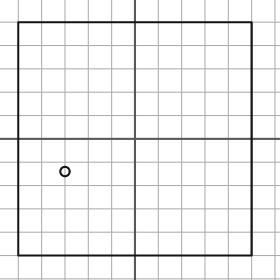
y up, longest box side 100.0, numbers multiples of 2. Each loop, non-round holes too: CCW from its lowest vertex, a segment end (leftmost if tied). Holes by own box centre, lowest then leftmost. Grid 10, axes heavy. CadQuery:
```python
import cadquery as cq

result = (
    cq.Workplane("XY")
    .moveTo(-50.0, -50.0)
    .lineTo(50.0, -50.0)
    .lineTo(50.0, 50.0)
    .lineTo(-50.0, 50.0)
    .close()
    .moveTo(-30.0, -14.0)
    .circle(2.0)
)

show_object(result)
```